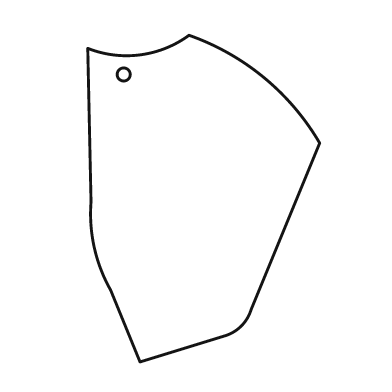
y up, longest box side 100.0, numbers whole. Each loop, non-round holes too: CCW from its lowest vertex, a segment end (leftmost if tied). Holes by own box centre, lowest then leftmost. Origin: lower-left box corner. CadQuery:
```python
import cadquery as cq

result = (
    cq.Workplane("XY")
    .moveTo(16.0, 0.0)
    .lineTo(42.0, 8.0)
    .threePointArc((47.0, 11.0), (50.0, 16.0))
    .lineTo(71.0, 67.0)
    .threePointArc((54.0, 87.0), (31.0, 100.0))
    .threePointArc((16.0, 94.0), (0.0, 96.0))
    .lineTo(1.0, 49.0)
    .threePointArc((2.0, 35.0), (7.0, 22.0))
    .close()
    .moveTo(11.0, 88.0)
    .circle(2.0)
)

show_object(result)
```